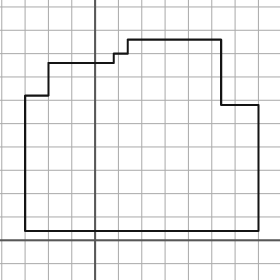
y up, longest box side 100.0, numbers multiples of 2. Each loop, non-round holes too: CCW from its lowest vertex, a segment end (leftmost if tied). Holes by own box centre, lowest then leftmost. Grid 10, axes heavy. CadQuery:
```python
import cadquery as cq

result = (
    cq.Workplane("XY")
    .moveTo(-30.0, 4.0)
    .lineTo(70.0, 4.0)
    .lineTo(70.0, 58.0)
    .lineTo(54.0, 58.0)
    .lineTo(54.0, 86.0)
    .lineTo(14.0, 86.0)
    .lineTo(14.0, 80.0)
    .lineTo(8.0, 80.0)
    .lineTo(8.0, 76.0)
    .lineTo(-20.0, 76.0)
    .lineTo(-20.0, 62.0)
    .lineTo(-30.0, 62.0)
    .close()
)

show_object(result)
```